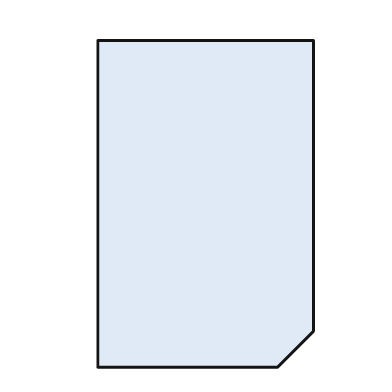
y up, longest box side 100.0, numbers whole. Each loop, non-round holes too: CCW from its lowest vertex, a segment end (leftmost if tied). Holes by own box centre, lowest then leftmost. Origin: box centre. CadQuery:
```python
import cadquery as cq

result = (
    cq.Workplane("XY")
    .moveTo(-33.0, -50.0)
    .lineTo(22.0, -50.0)
    .lineTo(33.0, -39.0)
    .lineTo(33.0, 50.0)
    .lineTo(-33.0, 50.0)
    .close()
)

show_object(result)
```